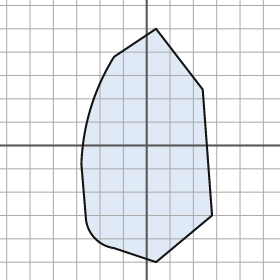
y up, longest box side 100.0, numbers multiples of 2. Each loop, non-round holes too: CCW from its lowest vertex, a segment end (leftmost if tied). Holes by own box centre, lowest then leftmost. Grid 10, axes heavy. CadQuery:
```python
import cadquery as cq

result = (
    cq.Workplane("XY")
    .moveTo(4.0, -50.0)
    .lineTo(28.0, -30.0)
    .lineTo(24.0, 24.0)
    .lineTo(4.0, 50.0)
    .lineTo(-14.0, 38.0)
    .threePointArc((-24.0, 16.0), (-28.0, -8.0))
    .lineTo(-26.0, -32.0)
    .threePointArc((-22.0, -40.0), (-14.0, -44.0))
    .close()
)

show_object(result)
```